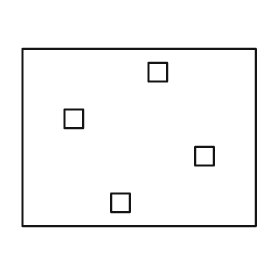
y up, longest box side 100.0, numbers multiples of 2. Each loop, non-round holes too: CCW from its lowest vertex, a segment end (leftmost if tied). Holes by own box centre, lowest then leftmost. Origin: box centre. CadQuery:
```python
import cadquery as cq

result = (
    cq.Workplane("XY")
    .moveTo(-50.0, -38.0)
    .lineTo(50.0, -38.0)
    .lineTo(50.0, 38.0)
    .lineTo(-50.0, 38.0)
    .close()
    .moveTo(-12.0, -32.0)
    .lineTo(-4.0, -32.0)
    .lineTo(-4.0, -24.0)
    .lineTo(-12.0, -24.0)
    .close()
    .moveTo(24.0, -12.0)
    .lineTo(32.0, -12.0)
    .lineTo(32.0, -4.0)
    .lineTo(24.0, -4.0)
    .close()
    .moveTo(-32.0, 4.0)
    .lineTo(-24.0, 4.0)
    .lineTo(-24.0, 12.0)
    .lineTo(-32.0, 12.0)
    .close()
    .moveTo(4.0, 24.0)
    .lineTo(12.0, 24.0)
    .lineTo(12.0, 32.0)
    .lineTo(4.0, 32.0)
    .close()
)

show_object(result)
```